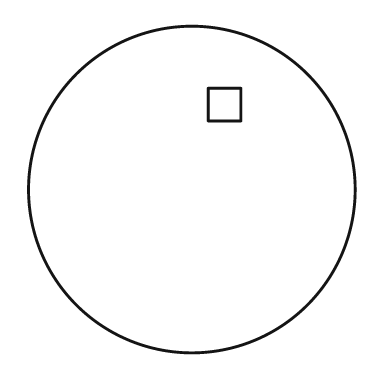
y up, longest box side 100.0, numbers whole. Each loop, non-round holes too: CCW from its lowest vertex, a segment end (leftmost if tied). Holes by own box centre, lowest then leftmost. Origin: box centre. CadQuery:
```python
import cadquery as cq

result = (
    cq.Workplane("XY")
    .moveTo(0.0, 0.0)
    .circle(50.0)
    .moveTo(5.0, 21.0)
    .lineTo(15.0, 21.0)
    .lineTo(15.0, 31.0)
    .lineTo(5.0, 31.0)
    .close()
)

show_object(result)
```